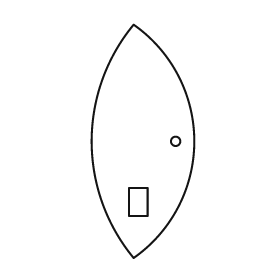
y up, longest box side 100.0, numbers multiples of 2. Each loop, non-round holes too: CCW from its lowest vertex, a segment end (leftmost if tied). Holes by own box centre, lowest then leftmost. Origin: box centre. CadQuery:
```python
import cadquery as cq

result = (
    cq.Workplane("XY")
    .moveTo(-4.0, -50.0)
    .threePointArc((22.0, 0.0), (-4.0, 50.0))
    .threePointArc((-22.0, 0.0), (-4.0, -50.0))
    .close()
    .moveTo(-6.0, -32.0)
    .lineTo(2.0, -32.0)
    .lineTo(2.0, -20.0)
    .lineTo(-6.0, -20.0)
    .close()
    .moveTo(14.0, 0.0)
    .circle(2.0)
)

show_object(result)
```